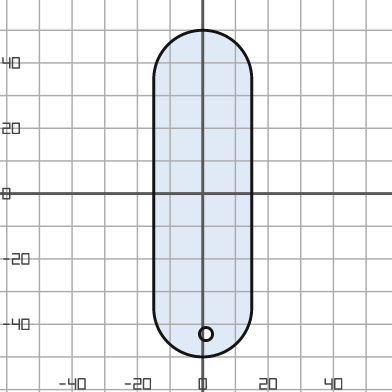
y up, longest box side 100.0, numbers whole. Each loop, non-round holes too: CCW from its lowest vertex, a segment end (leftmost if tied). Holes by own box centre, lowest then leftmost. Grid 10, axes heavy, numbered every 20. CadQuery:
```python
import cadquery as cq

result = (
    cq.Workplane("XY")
    .moveTo(-15.0, -35.0)
    .threePointArc((0.0, -50.0), (15.0, -35.0))
    .lineTo(15.0, 35.0)
    .threePointArc((0.0, 50.0), (-15.0, 35.0))
    .close()
    .moveTo(1.0, -43.0)
    .circle(2.0)
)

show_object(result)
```